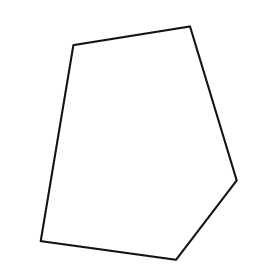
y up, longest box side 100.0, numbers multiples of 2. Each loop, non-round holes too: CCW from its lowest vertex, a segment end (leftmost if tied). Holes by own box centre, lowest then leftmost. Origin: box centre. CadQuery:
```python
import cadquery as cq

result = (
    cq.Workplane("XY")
    .moveTo(16.0, -50.0)
    .lineTo(42.0, -16.0)
    .lineTo(22.0, 50.0)
    .lineTo(-28.0, 42.0)
    .lineTo(-42.0, -42.0)
    .close()
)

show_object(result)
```